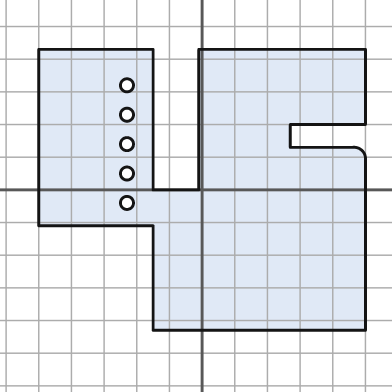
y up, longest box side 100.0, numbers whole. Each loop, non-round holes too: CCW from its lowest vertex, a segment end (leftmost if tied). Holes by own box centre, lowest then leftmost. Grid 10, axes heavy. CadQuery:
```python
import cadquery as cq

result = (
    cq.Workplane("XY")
    .moveTo(-15.0, -43.0)
    .lineTo(50.0, -43.0)
    .lineTo(50.0, 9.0)
    .threePointArc((49.0, 12.0), (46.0, 13.0))
    .lineTo(27.0, 13.0)
    .lineTo(27.0, 20.0)
    .lineTo(50.0, 20.0)
    .lineTo(50.0, 43.0)
    .lineTo(-1.0, 43.0)
    .lineTo(-1.0, 0.0)
    .lineTo(-15.0, 0.0)
    .lineTo(-15.0, 43.0)
    .lineTo(-50.0, 43.0)
    .lineTo(-50.0, -11.0)
    .lineTo(-15.0, -11.0)
    .close()
    .moveTo(-23.0, -4.0)
    .circle(2.0)
    .moveTo(-23.0, 5.0)
    .circle(2.0)
    .moveTo(-23.0, 14.0)
    .circle(2.0)
    .moveTo(-23.0, 23.0)
    .circle(2.0)
    .moveTo(-23.0, 32.0)
    .circle(2.0)
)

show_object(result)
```